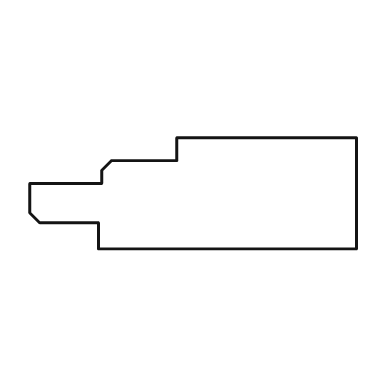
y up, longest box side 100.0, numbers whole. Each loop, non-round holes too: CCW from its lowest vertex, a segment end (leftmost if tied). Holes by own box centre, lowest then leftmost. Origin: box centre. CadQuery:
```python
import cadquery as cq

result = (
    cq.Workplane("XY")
    .moveTo(-29.0, -17.0)
    .lineTo(50.0, -17.0)
    .lineTo(50.0, 17.0)
    .lineTo(-5.0, 17.0)
    .lineTo(-5.0, 10.0)
    .lineTo(-25.0, 10.0)
    .lineTo(-28.0, 7.0)
    .lineTo(-28.0, 3.0)
    .lineTo(-50.0, 3.0)
    .lineTo(-50.0, -6.0)
    .lineTo(-47.0, -9.0)
    .lineTo(-29.0, -9.0)
    .close()
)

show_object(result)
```